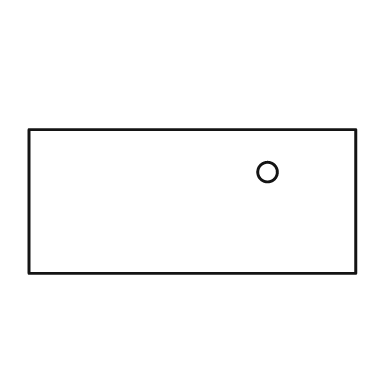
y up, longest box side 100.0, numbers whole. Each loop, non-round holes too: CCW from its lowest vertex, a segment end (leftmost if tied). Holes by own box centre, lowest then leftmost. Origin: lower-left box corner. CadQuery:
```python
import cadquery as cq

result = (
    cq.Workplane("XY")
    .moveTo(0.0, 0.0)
    .lineTo(100.0, 0.0)
    .lineTo(100.0, 44.0)
    .lineTo(0.0, 44.0)
    .close()
    .moveTo(73.0, 31.0)
    .circle(3.0)
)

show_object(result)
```